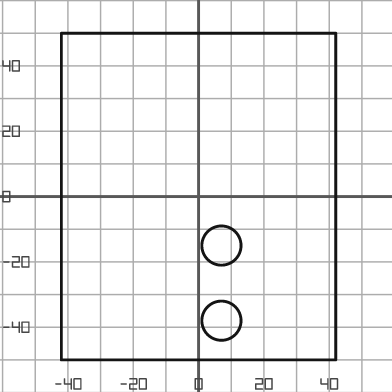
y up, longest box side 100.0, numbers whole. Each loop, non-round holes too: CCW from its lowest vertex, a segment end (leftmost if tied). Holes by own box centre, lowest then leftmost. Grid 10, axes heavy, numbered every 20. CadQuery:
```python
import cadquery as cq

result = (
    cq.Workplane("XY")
    .moveTo(-42.0, -50.0)
    .lineTo(42.0, -50.0)
    .lineTo(42.0, 50.0)
    .lineTo(-42.0, 50.0)
    .close()
    .moveTo(7.0, -38.0)
    .circle(6.0)
    .moveTo(7.0, -15.0)
    .circle(6.0)
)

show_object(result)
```